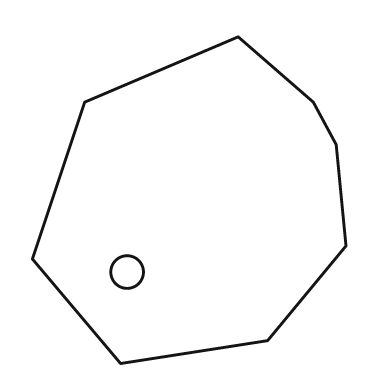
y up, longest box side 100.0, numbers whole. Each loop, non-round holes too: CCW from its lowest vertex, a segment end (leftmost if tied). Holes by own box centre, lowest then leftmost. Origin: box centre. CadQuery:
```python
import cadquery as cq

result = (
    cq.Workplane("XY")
    .moveTo(-21.0, -50.0)
    .lineTo(24.0, -43.0)
    .lineTo(48.0, -14.0)
    .lineTo(45.0, 17.0)
    .lineTo(38.0, 30.0)
    .lineTo(15.0, 50.0)
    .lineTo(-32.0, 30.0)
    .lineTo(-48.0, -18.0)
    .close()
    .moveTo(-19.0, -22.0)
    .circle(5.0)
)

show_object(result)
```